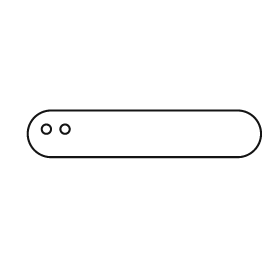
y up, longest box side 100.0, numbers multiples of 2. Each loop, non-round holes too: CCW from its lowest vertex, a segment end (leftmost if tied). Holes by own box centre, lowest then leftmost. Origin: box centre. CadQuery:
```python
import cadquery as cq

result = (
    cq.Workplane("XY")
    .moveTo(-40.0, -10.0)
    .lineTo(40.0, -10.0)
    .threePointArc((50.0, 0.0), (40.0, 10.0))
    .lineTo(-40.0, 10.0)
    .threePointArc((-50.0, 0.0), (-40.0, -10.0))
    .close()
    .moveTo(-42.0, 2.0)
    .circle(2.0)
    .moveTo(-34.0, 2.0)
    .circle(2.0)
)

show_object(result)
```